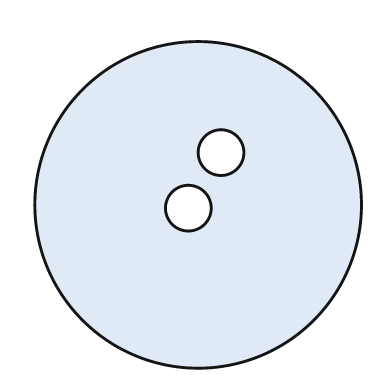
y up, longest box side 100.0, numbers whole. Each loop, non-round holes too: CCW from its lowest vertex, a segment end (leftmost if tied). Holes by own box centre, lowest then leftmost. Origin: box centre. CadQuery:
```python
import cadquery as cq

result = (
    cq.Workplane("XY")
    .moveTo(0.0, 0.0)
    .circle(50.0)
    .moveTo(-3.0, -1.0)
    .circle(7.0)
    .moveTo(7.0, 16.0)
    .circle(7.0)
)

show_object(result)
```